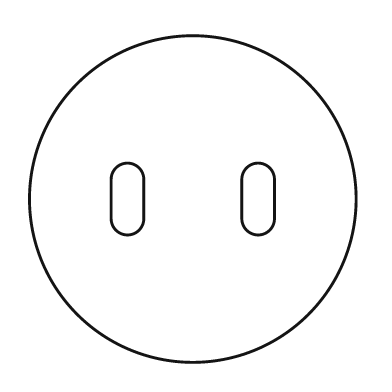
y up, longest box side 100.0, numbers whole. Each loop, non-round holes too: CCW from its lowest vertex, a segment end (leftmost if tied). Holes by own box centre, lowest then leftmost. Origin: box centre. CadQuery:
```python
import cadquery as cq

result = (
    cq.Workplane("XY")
    .moveTo(0.0, 0.0)
    .circle(50.0)
    .moveTo(-25.0, -6.0)
    .threePointArc((-20.0, -11.0), (-15.0, -6.0))
    .lineTo(-15.0, 6.0)
    .threePointArc((-20.0, 11.0), (-25.0, 6.0))
    .close()
    .moveTo(15.0, -6.0)
    .threePointArc((20.0, -11.0), (25.0, -6.0))
    .lineTo(25.0, 6.0)
    .threePointArc((20.0, 11.0), (15.0, 6.0))
    .close()
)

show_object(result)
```